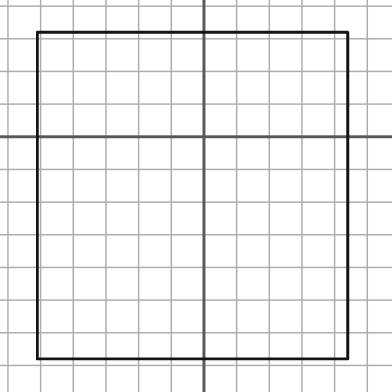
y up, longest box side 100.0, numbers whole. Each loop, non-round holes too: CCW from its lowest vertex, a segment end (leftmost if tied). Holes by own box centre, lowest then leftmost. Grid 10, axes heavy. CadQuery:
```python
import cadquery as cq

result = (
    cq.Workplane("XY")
    .moveTo(-51.0, -68.0)
    .lineTo(44.0, -68.0)
    .lineTo(44.0, 32.0)
    .lineTo(-51.0, 32.0)
    .close()
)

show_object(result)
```